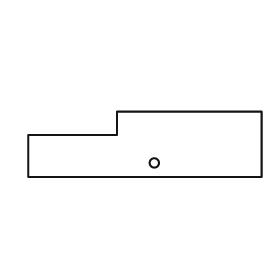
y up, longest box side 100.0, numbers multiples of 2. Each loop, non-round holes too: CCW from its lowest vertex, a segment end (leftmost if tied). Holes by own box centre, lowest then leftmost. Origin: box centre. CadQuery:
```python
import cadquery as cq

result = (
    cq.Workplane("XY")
    .moveTo(-50.0, -14.0)
    .lineTo(50.0, -14.0)
    .lineTo(50.0, 14.0)
    .lineTo(-12.0, 14.0)
    .lineTo(-12.0, 4.0)
    .lineTo(-50.0, 4.0)
    .close()
    .moveTo(4.0, -8.0)
    .circle(2.0)
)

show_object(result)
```